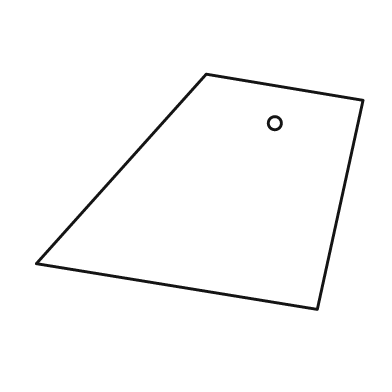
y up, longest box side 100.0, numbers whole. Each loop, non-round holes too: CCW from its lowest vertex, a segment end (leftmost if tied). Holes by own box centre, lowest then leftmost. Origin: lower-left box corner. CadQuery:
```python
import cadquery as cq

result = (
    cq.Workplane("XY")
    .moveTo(86.0, 0.0)
    .lineTo(100.0, 64.0)
    .lineTo(52.0, 72.0)
    .lineTo(0.0, 14.0)
    .close()
    .moveTo(73.0, 57.0)
    .circle(2.0)
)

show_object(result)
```